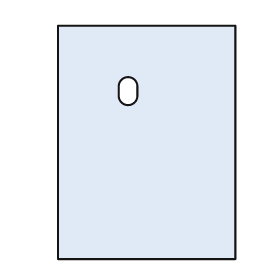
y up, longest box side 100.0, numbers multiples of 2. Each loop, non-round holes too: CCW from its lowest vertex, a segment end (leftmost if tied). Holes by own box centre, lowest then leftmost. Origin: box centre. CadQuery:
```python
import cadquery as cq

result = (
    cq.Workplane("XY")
    .moveTo(-38.0, -50.0)
    .lineTo(38.0, -50.0)
    .lineTo(38.0, 50.0)
    .lineTo(-38.0, 50.0)
    .close()
    .moveTo(-12.0, 20.0)
    .threePointArc((-8.0, 16.0), (-4.0, 20.0))
    .lineTo(-4.0, 24.0)
    .threePointArc((-8.0, 28.0), (-12.0, 24.0))
    .close()
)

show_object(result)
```